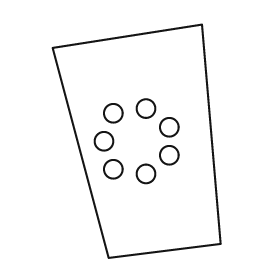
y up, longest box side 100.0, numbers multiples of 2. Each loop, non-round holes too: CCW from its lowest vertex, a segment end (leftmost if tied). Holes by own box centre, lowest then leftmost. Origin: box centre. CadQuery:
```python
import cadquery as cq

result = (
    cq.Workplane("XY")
    .moveTo(-12.0, -50.0)
    .lineTo(36.0, -44.0)
    .lineTo(28.0, 50.0)
    .lineTo(-36.0, 40.0)
    .close()
    .moveTo(4.0, -14.0)
    .circle(4.0)
    .moveTo(-10.0, -12.0)
    .circle(4.0)
    .moveTo(14.0, -6.0)
    .circle(4.0)
    .moveTo(-14.0, 0.0)
    .circle(4.0)
    .moveTo(14.0, 6.0)
    .circle(4.0)
    .moveTo(-10.0, 12.0)
    .circle(4.0)
    .moveTo(4.0, 14.0)
    .circle(4.0)
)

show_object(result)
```